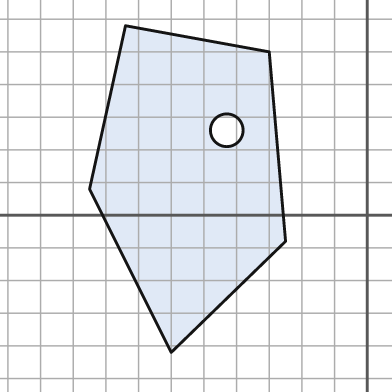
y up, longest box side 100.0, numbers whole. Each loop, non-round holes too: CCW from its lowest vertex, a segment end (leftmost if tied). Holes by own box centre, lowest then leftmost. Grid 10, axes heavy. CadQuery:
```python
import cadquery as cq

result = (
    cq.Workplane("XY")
    .moveTo(-60.0, -42.0)
    .lineTo(-25.0, -8.0)
    .lineTo(-30.0, 50.0)
    .lineTo(-74.0, 58.0)
    .lineTo(-85.0, 8.0)
    .close()
    .moveTo(-43.0, 26.0)
    .circle(5.0)
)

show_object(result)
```